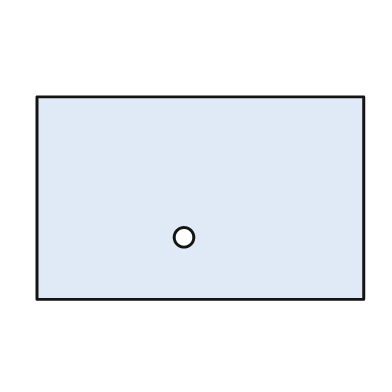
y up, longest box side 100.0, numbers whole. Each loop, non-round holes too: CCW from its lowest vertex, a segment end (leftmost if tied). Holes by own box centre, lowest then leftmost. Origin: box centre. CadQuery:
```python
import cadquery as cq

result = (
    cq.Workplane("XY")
    .moveTo(-50.0, -31.0)
    .lineTo(50.0, -31.0)
    .lineTo(50.0, 31.0)
    .lineTo(-50.0, 31.0)
    .close()
    .moveTo(-5.0, -12.0)
    .circle(3.0)
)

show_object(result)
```